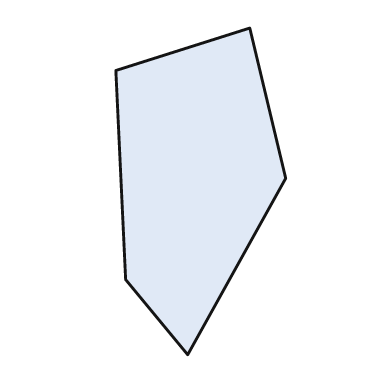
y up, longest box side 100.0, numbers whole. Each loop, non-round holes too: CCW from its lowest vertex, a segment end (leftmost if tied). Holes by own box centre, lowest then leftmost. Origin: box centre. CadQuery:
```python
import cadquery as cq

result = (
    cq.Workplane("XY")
    .moveTo(-4.0, -50.0)
    .lineTo(26.0, 4.0)
    .lineTo(15.0, 50.0)
    .lineTo(-26.0, 37.0)
    .lineTo(-23.0, -27.0)
    .close()
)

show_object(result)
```